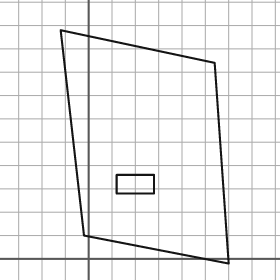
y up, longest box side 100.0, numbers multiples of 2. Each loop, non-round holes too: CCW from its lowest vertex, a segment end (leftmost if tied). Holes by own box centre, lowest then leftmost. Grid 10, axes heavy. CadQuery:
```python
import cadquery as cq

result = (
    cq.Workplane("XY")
    .moveTo(60.0, -2.0)
    .lineTo(54.0, 84.0)
    .lineTo(-12.0, 98.0)
    .lineTo(-2.0, 10.0)
    .close()
    .moveTo(12.0, 28.0)
    .lineTo(28.0, 28.0)
    .lineTo(28.0, 36.0)
    .lineTo(12.0, 36.0)
    .close()
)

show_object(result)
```